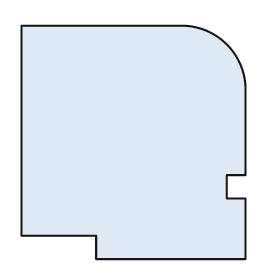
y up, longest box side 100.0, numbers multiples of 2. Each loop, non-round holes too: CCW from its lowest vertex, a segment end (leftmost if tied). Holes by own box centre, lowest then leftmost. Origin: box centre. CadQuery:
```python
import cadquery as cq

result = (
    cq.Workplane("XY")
    .moveTo(-16.0, -50.0)
    .lineTo(48.0, -50.0)
    .lineTo(48.0, -24.0)
    .lineTo(40.0, -24.0)
    .lineTo(40.0, -14.0)
    .lineTo(48.0, -14.0)
    .lineTo(48.0, 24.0)
    .threePointArc((40.0, 42.0), (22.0, 50.0))
    .lineTo(-48.0, 50.0)
    .lineTo(-48.0, -40.0)
    .lineTo(-16.0, -40.0)
    .close()
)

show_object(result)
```